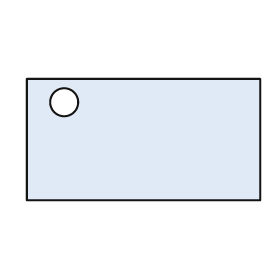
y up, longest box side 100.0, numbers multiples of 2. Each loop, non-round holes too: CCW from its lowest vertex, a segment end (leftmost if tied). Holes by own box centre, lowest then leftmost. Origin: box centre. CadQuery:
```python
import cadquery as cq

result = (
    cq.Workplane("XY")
    .moveTo(-50.0, -26.0)
    .lineTo(50.0, -26.0)
    .lineTo(50.0, 26.0)
    .lineTo(-50.0, 26.0)
    .close()
    .moveTo(-34.0, 16.0)
    .circle(6.0)
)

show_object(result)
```